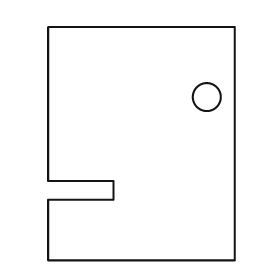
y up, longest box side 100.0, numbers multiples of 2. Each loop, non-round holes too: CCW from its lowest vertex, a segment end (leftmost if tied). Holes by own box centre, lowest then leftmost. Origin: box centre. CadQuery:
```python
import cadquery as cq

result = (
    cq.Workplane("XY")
    .moveTo(-40.0, -50.0)
    .lineTo(40.0, -50.0)
    .lineTo(40.0, 50.0)
    .lineTo(-40.0, 50.0)
    .lineTo(-40.0, -16.0)
    .lineTo(-12.0, -16.0)
    .lineTo(-12.0, -24.0)
    .lineTo(-40.0, -24.0)
    .close()
    .moveTo(28.0, 20.0)
    .circle(6.0)
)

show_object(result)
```